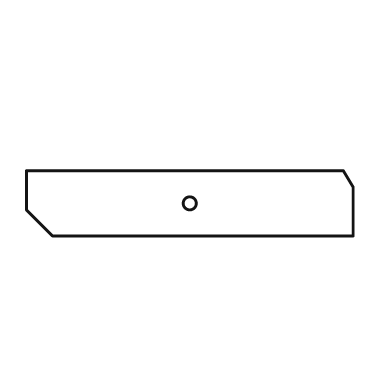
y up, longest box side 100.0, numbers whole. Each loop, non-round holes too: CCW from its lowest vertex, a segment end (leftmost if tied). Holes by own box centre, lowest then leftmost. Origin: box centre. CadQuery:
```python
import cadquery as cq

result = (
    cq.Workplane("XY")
    .moveTo(-42.0, -10.0)
    .lineTo(50.0, -10.0)
    .lineTo(50.0, 5.0)
    .lineTo(47.0, 10.0)
    .lineTo(-50.0, 10.0)
    .lineTo(-50.0, -2.0)
    .close()
    .moveTo(0.0, 0.0)
    .circle(2.0)
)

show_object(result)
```